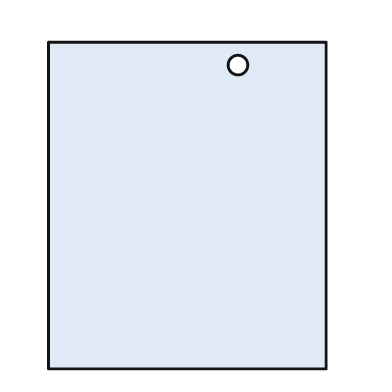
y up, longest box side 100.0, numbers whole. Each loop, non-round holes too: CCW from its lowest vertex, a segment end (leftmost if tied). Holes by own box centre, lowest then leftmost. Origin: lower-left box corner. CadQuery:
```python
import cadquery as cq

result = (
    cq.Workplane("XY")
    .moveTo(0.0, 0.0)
    .lineTo(85.0, 0.0)
    .lineTo(85.0, 100.0)
    .lineTo(0.0, 100.0)
    .close()
    .moveTo(58.0, 93.0)
    .circle(3.0)
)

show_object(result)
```